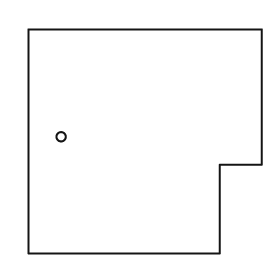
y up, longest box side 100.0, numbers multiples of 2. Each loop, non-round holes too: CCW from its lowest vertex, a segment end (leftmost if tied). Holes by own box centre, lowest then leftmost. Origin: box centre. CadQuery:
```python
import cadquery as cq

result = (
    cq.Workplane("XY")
    .moveTo(-50.0, -48.0)
    .lineTo(32.0, -48.0)
    .lineTo(32.0, -10.0)
    .lineTo(50.0, -10.0)
    .lineTo(50.0, 48.0)
    .lineTo(-50.0, 48.0)
    .close()
    .moveTo(-36.0, 2.0)
    .circle(2.0)
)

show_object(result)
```